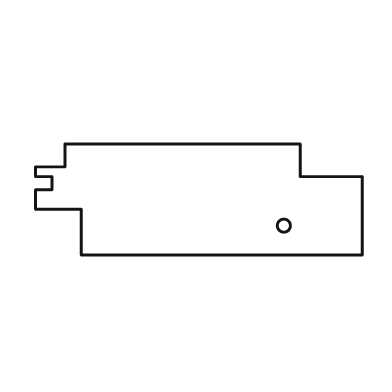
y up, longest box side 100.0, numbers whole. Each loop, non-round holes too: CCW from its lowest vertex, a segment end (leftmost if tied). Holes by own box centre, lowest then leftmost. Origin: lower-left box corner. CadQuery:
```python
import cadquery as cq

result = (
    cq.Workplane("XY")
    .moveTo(14.0, 0.0)
    .lineTo(100.0, 0.0)
    .lineTo(100.0, 24.0)
    .lineTo(81.0, 24.0)
    .lineTo(81.0, 34.0)
    .lineTo(9.0, 34.0)
    .lineTo(9.0, 27.0)
    .lineTo(0.0, 27.0)
    .lineTo(0.0, 24.0)
    .lineTo(5.0, 24.0)
    .lineTo(5.0, 20.0)
    .lineTo(0.0, 20.0)
    .lineTo(0.0, 14.0)
    .lineTo(14.0, 14.0)
    .close()
    .moveTo(76.0, 9.0)
    .circle(2.0)
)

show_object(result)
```